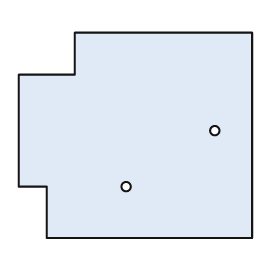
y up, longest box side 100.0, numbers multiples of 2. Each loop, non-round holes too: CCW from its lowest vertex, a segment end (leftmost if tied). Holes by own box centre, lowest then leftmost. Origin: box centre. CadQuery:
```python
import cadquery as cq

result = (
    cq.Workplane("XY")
    .moveTo(-38.0, -44.0)
    .lineTo(50.0, -44.0)
    .lineTo(50.0, 44.0)
    .lineTo(-26.0, 44.0)
    .lineTo(-26.0, 26.0)
    .lineTo(-50.0, 26.0)
    .lineTo(-50.0, -22.0)
    .lineTo(-38.0, -22.0)
    .close()
    .moveTo(-4.0, -22.0)
    .circle(2.0)
    .moveTo(34.0, 2.0)
    .circle(2.0)
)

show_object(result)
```